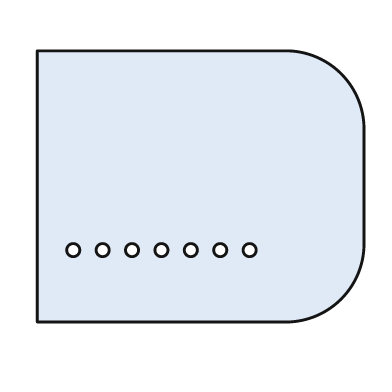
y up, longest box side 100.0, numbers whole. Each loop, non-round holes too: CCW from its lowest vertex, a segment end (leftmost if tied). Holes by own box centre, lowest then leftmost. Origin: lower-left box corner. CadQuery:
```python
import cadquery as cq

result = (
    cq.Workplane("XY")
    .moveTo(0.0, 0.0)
    .lineTo(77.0, 0.0)
    .threePointArc((93.0, 7.0), (100.0, 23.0))
    .lineTo(100.0, 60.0)
    .threePointArc((93.0, 76.0), (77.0, 83.0))
    .lineTo(0.0, 83.0)
    .close()
    .moveTo(11.0, 22.0)
    .circle(2.0)
    .moveTo(20.0, 22.0)
    .circle(2.0)
    .moveTo(29.0, 22.0)
    .circle(2.0)
    .moveTo(38.0, 22.0)
    .circle(2.0)
    .moveTo(47.0, 22.0)
    .circle(2.0)
    .moveTo(56.0, 22.0)
    .circle(2.0)
    .moveTo(65.0, 22.0)
    .circle(2.0)
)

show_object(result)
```